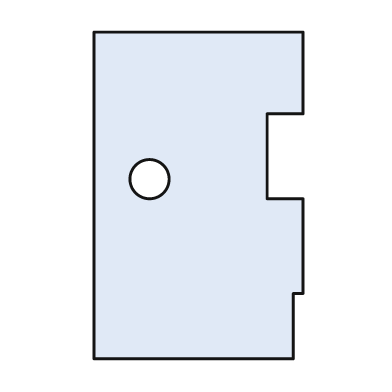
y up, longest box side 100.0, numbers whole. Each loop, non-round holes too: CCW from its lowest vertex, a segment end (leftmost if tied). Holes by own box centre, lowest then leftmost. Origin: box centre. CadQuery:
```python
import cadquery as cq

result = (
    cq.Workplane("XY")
    .moveTo(-32.0, -50.0)
    .lineTo(29.0, -50.0)
    .lineTo(29.0, -30.0)
    .lineTo(32.0, -30.0)
    .lineTo(32.0, -1.0)
    .lineTo(21.0, -1.0)
    .lineTo(21.0, 25.0)
    .lineTo(32.0, 25.0)
    .lineTo(32.0, 50.0)
    .lineTo(-32.0, 50.0)
    .close()
    .moveTo(-15.0, 5.0)
    .circle(6.0)
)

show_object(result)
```